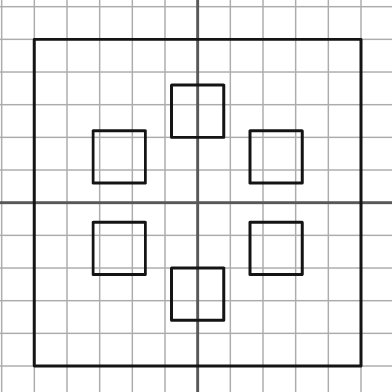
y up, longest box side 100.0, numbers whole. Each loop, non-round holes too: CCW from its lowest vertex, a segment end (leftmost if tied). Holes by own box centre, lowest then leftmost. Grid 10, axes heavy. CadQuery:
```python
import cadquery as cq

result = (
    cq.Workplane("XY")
    .moveTo(-50.0, -50.0)
    .lineTo(50.0, -50.0)
    .lineTo(50.0, 50.0)
    .lineTo(-50.0, 50.0)
    .close()
    .moveTo(-8.0, -36.0)
    .lineTo(8.0, -36.0)
    .lineTo(8.0, -20.0)
    .lineTo(-8.0, -20.0)
    .close()
    .moveTo(-32.0, -22.0)
    .lineTo(-16.0, -22.0)
    .lineTo(-16.0, -6.0)
    .lineTo(-32.0, -6.0)
    .close()
    .moveTo(16.0, -22.0)
    .lineTo(32.0, -22.0)
    .lineTo(32.0, -6.0)
    .lineTo(16.0, -6.0)
    .close()
    .moveTo(-32.0, 6.0)
    .lineTo(-16.0, 6.0)
    .lineTo(-16.0, 22.0)
    .lineTo(-32.0, 22.0)
    .close()
    .moveTo(16.0, 6.0)
    .lineTo(32.0, 6.0)
    .lineTo(32.0, 22.0)
    .lineTo(16.0, 22.0)
    .close()
    .moveTo(-8.0, 20.0)
    .lineTo(8.0, 20.0)
    .lineTo(8.0, 36.0)
    .lineTo(-8.0, 36.0)
    .close()
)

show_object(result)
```